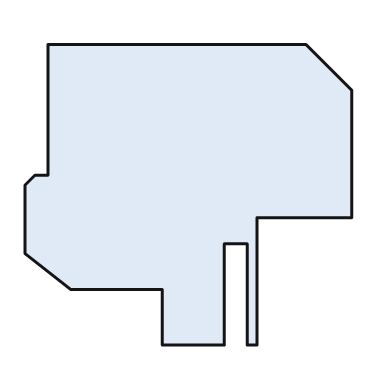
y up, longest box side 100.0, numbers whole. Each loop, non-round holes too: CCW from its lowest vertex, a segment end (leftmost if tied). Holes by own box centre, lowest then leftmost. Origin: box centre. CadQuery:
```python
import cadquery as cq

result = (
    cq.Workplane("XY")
    .moveTo(-8.0, -46.0)
    .lineTo(11.0, -46.0)
    .lineTo(11.0, -15.0)
    .lineTo(18.0, -15.0)
    .lineTo(18.0, -46.0)
    .lineTo(21.0, -46.0)
    .lineTo(21.0, -7.0)
    .lineTo(50.0, -7.0)
    .lineTo(50.0, 32.0)
    .lineTo(36.0, 46.0)
    .lineTo(-43.0, 46.0)
    .lineTo(-43.0, 6.0)
    .lineTo(-47.0, 6.0)
    .lineTo(-50.0, 3.0)
    .lineTo(-50.0, -18.0)
    .lineTo(-36.0, -29.0)
    .lineTo(-8.0, -29.0)
    .close()
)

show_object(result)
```